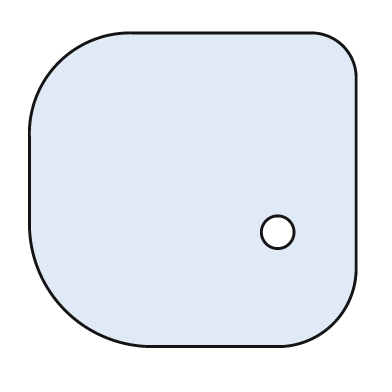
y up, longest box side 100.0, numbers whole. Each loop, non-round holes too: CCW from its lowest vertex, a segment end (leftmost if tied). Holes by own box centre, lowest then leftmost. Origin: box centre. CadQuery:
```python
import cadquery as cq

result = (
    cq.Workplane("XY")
    .moveTo(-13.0, -48.0)
    .lineTo(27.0, -48.0)
    .threePointArc((43.0, -41.0), (50.0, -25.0))
    .lineTo(50.0, 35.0)
    .threePointArc((46.0, 44.0), (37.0, 48.0))
    .lineTo(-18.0, 48.0)
    .threePointArc((-41.0, 39.0), (-50.0, 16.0))
    .lineTo(-50.0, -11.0)
    .threePointArc((-39.0, -37.0), (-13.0, -48.0))
    .close()
    .moveTo(26.0, -13.0)
    .circle(5.0)
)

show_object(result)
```